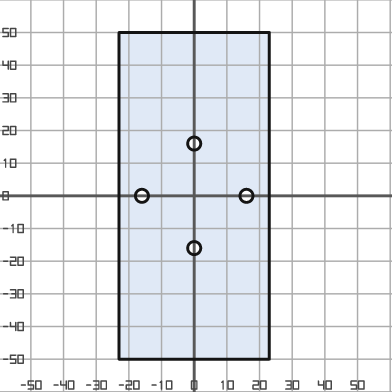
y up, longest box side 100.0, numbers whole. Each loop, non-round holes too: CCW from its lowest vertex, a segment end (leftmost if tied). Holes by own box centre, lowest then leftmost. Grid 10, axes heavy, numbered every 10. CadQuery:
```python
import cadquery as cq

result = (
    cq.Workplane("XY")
    .moveTo(-23.0, -50.0)
    .lineTo(23.0, -50.0)
    .lineTo(23.0, 50.0)
    .lineTo(-23.0, 50.0)
    .close()
    .moveTo(0.0, -16.0)
    .circle(2.0)
    .moveTo(-16.0, 0.0)
    .circle(2.0)
    .moveTo(16.0, 0.0)
    .circle(2.0)
    .moveTo(0.0, 16.0)
    .circle(2.0)
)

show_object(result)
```